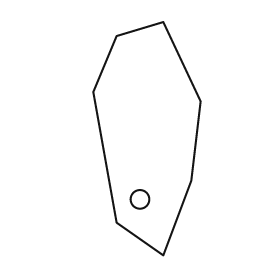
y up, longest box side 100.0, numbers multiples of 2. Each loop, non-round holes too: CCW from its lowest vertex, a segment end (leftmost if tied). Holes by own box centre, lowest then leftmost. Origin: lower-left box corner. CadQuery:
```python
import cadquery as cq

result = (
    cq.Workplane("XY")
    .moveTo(30.0, 0.0)
    .lineTo(42.0, 32.0)
    .lineTo(46.0, 66.0)
    .lineTo(30.0, 100.0)
    .lineTo(10.0, 94.0)
    .lineTo(0.0, 70.0)
    .lineTo(10.0, 14.0)
    .close()
    .moveTo(20.0, 24.0)
    .circle(4.0)
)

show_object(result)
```